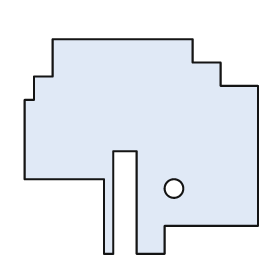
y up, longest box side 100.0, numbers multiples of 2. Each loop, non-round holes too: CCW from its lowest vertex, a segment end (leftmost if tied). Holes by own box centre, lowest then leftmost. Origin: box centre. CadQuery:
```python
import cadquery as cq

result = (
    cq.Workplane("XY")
    .moveTo(-16.0, -46.0)
    .lineTo(-12.0, -46.0)
    .lineTo(-12.0, -2.0)
    .lineTo(-2.0, -2.0)
    .lineTo(-2.0, -46.0)
    .lineTo(10.0, -46.0)
    .lineTo(10.0, -34.0)
    .lineTo(50.0, -34.0)
    .lineTo(50.0, 26.0)
    .lineTo(34.0, 26.0)
    .lineTo(34.0, 36.0)
    .lineTo(22.0, 36.0)
    .lineTo(22.0, 46.0)
    .lineTo(-38.0, 46.0)
    .lineTo(-38.0, 30.0)
    .lineTo(-46.0, 30.0)
    .lineTo(-46.0, 20.0)
    .lineTo(-50.0, 20.0)
    .lineTo(-50.0, -14.0)
    .lineTo(-16.0, -14.0)
    .close()
    .moveTo(14.0, -18.0)
    .circle(4.0)
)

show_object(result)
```